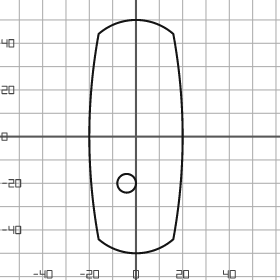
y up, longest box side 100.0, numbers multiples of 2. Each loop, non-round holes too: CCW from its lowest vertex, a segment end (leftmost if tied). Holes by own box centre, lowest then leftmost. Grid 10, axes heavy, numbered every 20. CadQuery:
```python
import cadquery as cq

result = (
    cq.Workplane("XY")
    .moveTo(-16.0, -44.0)
    .threePointArc((0.0, -50.0), (16.0, -44.0))
    .threePointArc((20.0, 0.0), (16.0, 44.0))
    .threePointArc((0.0, 50.0), (-16.0, 44.0))
    .threePointArc((-20.0, 0.0), (-16.0, -44.0))
    .close()
    .moveTo(-4.0, -20.0)
    .circle(4.0)
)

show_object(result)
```